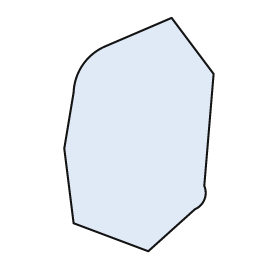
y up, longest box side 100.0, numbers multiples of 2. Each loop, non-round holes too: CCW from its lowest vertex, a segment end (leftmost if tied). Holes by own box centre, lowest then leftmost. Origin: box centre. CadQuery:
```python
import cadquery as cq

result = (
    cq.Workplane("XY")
    .moveTo(4.0, -50.0)
    .lineTo(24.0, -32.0)
    .threePointArc((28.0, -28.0), (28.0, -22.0))
    .lineTo(32.0, 26.0)
    .lineTo(14.0, 50.0)
    .lineTo(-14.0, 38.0)
    .threePointArc((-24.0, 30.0), (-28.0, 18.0))
    .lineTo(-32.0, -6.0)
    .lineTo(-28.0, -38.0)
    .close()
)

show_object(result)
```